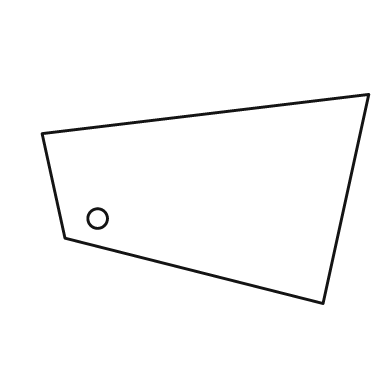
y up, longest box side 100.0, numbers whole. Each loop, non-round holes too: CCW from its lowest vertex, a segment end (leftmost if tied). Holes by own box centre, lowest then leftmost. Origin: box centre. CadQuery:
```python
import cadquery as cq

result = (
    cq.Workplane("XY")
    .moveTo(36.0, -32.0)
    .lineTo(50.0, 32.0)
    .lineTo(-50.0, 20.0)
    .lineTo(-43.0, -12.0)
    .close()
    .moveTo(-33.0, -6.0)
    .circle(3.0)
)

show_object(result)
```